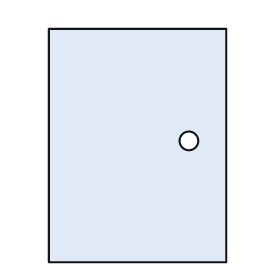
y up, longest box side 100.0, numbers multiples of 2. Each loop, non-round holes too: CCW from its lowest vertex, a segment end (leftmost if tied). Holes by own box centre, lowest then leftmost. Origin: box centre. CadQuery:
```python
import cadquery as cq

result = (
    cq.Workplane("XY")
    .moveTo(-38.0, -50.0)
    .lineTo(38.0, -50.0)
    .lineTo(38.0, 50.0)
    .lineTo(-38.0, 50.0)
    .close()
    .moveTo(22.0, 2.0)
    .circle(4.0)
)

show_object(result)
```